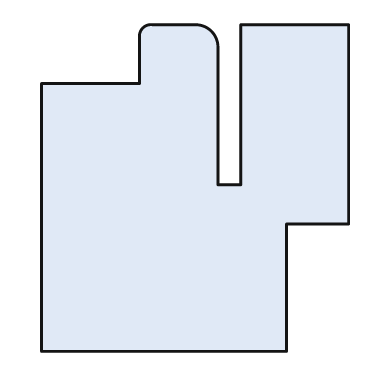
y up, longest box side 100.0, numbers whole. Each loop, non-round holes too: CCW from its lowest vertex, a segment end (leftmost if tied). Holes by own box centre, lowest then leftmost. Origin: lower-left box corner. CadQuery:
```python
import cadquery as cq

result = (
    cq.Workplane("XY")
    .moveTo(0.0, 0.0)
    .lineTo(75.0, 0.0)
    .lineTo(75.0, 39.0)
    .lineTo(94.0, 39.0)
    .lineTo(94.0, 100.0)
    .lineTo(61.0, 100.0)
    .lineTo(61.0, 51.0)
    .lineTo(54.0, 51.0)
    .lineTo(54.0, 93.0)
    .threePointArc((52.0, 98.0), (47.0, 100.0))
    .lineTo(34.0, 100.0)
    .threePointArc((31.0, 99.0), (30.0, 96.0))
    .lineTo(30.0, 82.0)
    .lineTo(0.0, 82.0)
    .close()
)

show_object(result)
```